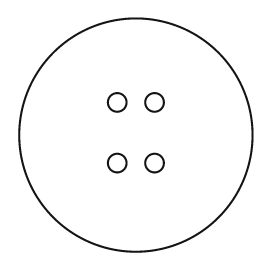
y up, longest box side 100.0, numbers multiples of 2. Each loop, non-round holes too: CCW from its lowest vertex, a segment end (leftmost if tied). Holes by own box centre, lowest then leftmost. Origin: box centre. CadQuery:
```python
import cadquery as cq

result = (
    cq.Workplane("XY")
    .moveTo(0.0, 0.0)
    .circle(50.0)
    .moveTo(-8.0, -12.0)
    .circle(4.0)
    .moveTo(8.0, -12.0)
    .circle(4.0)
    .moveTo(-8.0, 14.0)
    .circle(4.0)
    .moveTo(8.0, 14.0)
    .circle(4.0)
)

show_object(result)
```